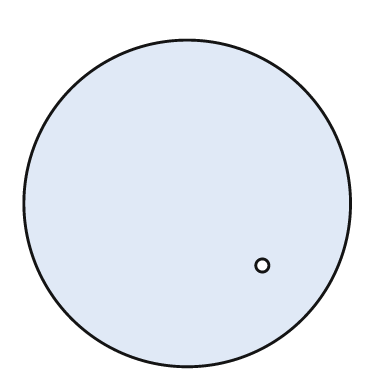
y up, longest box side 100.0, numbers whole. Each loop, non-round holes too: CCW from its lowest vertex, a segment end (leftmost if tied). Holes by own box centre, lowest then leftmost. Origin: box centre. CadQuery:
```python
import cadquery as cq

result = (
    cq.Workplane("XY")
    .moveTo(0.0, 0.0)
    .circle(50.0)
    .moveTo(23.0, -19.0)
    .circle(2.0)
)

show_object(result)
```